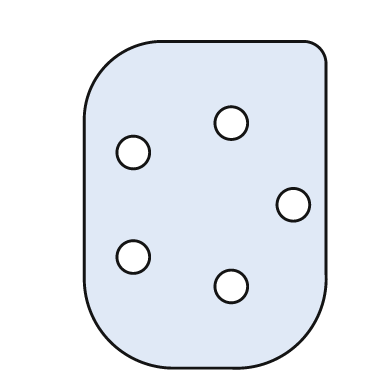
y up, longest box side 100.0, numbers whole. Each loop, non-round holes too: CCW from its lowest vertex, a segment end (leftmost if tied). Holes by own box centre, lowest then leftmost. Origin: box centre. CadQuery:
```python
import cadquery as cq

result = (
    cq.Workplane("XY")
    .moveTo(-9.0, -50.0)
    .lineTo(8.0, -50.0)
    .threePointArc((29.0, -42.0), (37.0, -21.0))
    .lineTo(37.0, 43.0)
    .threePointArc((35.0, 48.0), (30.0, 50.0))
    .lineTo(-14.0, 50.0)
    .threePointArc((-30.0, 43.0), (-37.0, 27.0))
    .lineTo(-37.0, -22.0)
    .threePointArc((-29.0, -42.0), (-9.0, -50.0))
    .close()
    .moveTo(8.0, -25.0)
    .circle(5.0)
    .moveTo(-22.0, -16.0)
    .circle(5.0)
    .moveTo(27.0, 0.0)
    .circle(5.0)
    .moveTo(-22.0, 16.0)
    .circle(5.0)
    .moveTo(8.0, 25.0)
    .circle(5.0)
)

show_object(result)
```